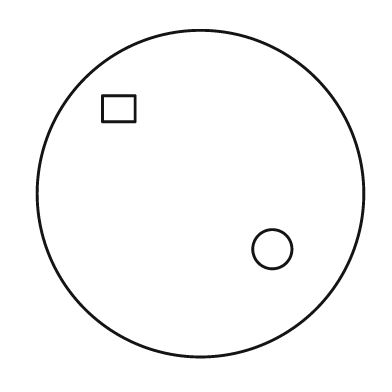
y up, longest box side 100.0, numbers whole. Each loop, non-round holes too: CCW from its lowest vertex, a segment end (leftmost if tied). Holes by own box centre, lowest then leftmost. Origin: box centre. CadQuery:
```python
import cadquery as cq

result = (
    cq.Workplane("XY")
    .moveTo(0.0, 0.0)
    .circle(50.0)
    .moveTo(22.0, -17.0)
    .circle(6.0)
    .moveTo(-30.0, 22.0)
    .lineTo(-20.0, 22.0)
    .lineTo(-20.0, 30.0)
    .lineTo(-30.0, 30.0)
    .close()
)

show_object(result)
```